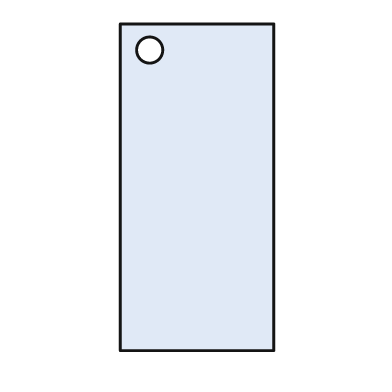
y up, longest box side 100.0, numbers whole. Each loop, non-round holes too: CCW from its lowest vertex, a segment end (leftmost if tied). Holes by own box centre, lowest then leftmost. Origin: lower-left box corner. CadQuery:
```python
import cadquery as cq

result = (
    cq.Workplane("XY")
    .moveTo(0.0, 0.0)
    .lineTo(47.0, 0.0)
    .lineTo(47.0, 100.0)
    .lineTo(0.0, 100.0)
    .close()
    .moveTo(9.0, 92.0)
    .circle(4.0)
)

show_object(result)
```